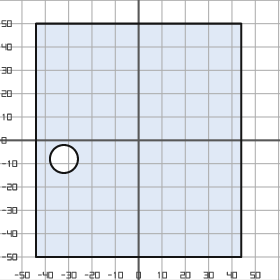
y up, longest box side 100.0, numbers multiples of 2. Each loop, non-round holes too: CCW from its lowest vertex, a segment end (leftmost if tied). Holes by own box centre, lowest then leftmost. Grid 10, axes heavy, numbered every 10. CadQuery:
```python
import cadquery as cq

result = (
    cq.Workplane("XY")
    .moveTo(-44.0, -50.0)
    .lineTo(44.0, -50.0)
    .lineTo(44.0, 50.0)
    .lineTo(-44.0, 50.0)
    .close()
    .moveTo(-32.0, -8.0)
    .circle(6.0)
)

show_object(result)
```